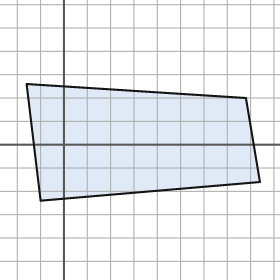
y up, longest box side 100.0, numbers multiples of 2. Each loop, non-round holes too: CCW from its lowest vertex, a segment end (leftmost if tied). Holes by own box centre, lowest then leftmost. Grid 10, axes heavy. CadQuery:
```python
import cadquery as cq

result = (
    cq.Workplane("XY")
    .moveTo(-10.0, -24.0)
    .lineTo(84.0, -16.0)
    .lineTo(78.0, 20.0)
    .lineTo(-16.0, 26.0)
    .close()
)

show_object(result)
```